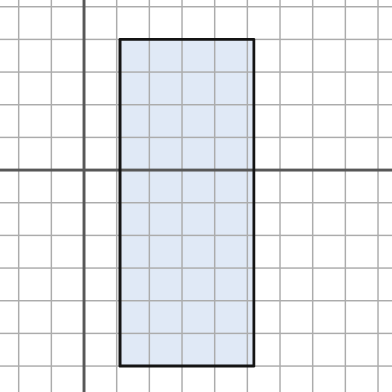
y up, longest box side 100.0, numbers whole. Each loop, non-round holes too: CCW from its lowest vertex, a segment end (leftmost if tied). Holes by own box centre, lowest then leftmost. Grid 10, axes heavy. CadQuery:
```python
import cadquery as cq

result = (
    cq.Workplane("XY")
    .moveTo(11.0, -60.0)
    .lineTo(52.0, -60.0)
    .lineTo(52.0, 40.0)
    .lineTo(11.0, 40.0)
    .close()
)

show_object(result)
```